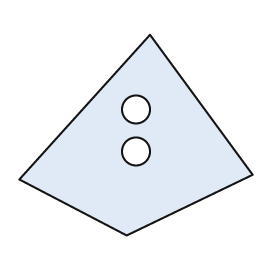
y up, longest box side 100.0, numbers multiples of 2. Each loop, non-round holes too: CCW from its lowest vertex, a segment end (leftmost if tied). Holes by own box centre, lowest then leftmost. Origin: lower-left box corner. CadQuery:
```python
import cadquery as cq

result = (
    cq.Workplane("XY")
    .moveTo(46.0, 0.0)
    .lineTo(100.0, 26.0)
    .lineTo(56.0, 86.0)
    .lineTo(0.0, 24.0)
    .close()
    .moveTo(50.0, 36.0)
    .circle(6.0)
    .moveTo(50.0, 54.0)
    .circle(6.0)
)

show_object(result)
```